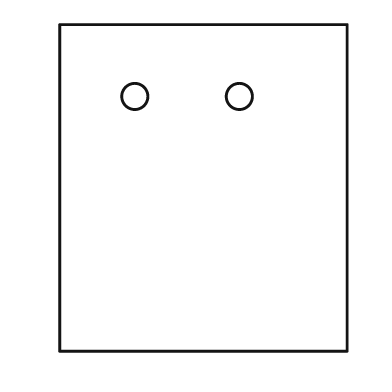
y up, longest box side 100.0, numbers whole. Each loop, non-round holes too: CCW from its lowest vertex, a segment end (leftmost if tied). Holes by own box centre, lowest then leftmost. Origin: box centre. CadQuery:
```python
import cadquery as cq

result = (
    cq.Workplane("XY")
    .moveTo(-44.0, -50.0)
    .lineTo(44.0, -50.0)
    .lineTo(44.0, 50.0)
    .lineTo(-44.0, 50.0)
    .close()
    .moveTo(-21.0, 28.0)
    .circle(4.0)
    .moveTo(11.0, 28.0)
    .circle(4.0)
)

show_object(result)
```